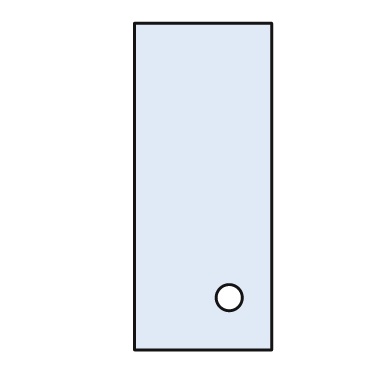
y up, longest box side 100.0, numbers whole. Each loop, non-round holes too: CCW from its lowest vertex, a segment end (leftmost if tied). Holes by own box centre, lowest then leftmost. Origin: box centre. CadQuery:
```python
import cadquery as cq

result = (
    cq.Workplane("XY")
    .moveTo(-21.0, -50.0)
    .lineTo(21.0, -50.0)
    .lineTo(21.0, 50.0)
    .lineTo(-21.0, 50.0)
    .close()
    .moveTo(8.0, -34.0)
    .circle(4.0)
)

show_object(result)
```